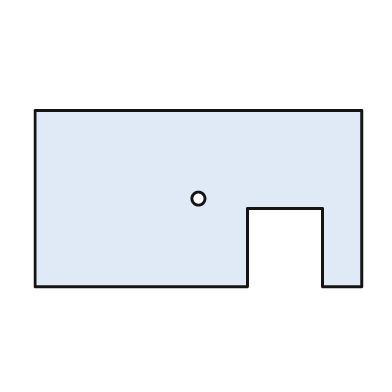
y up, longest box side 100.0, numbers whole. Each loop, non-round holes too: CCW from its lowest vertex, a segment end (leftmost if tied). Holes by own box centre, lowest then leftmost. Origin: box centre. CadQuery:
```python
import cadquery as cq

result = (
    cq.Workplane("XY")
    .moveTo(-50.0, -27.0)
    .lineTo(15.0, -27.0)
    .lineTo(15.0, -3.0)
    .lineTo(38.0, -3.0)
    .lineTo(38.0, -27.0)
    .lineTo(50.0, -27.0)
    .lineTo(50.0, 27.0)
    .lineTo(-50.0, 27.0)
    .close()
    .moveTo(0.0, 0.0)
    .circle(2.0)
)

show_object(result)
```